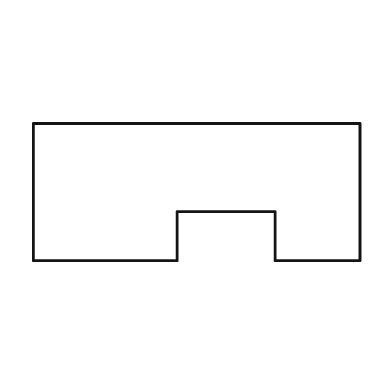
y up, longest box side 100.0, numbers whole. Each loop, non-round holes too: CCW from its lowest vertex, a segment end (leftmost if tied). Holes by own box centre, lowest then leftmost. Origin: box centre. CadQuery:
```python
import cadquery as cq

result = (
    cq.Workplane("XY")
    .moveTo(-50.0, -21.0)
    .lineTo(-6.0, -21.0)
    .lineTo(-6.0, -6.0)
    .lineTo(24.0, -6.0)
    .lineTo(24.0, -21.0)
    .lineTo(50.0, -21.0)
    .lineTo(50.0, 21.0)
    .lineTo(-50.0, 21.0)
    .close()
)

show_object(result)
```